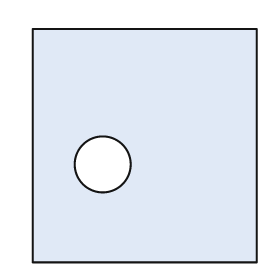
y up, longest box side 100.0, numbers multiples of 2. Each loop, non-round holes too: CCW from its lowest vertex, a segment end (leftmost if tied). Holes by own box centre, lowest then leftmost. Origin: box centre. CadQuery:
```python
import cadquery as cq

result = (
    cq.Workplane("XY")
    .moveTo(-48.0, -50.0)
    .lineTo(48.0, -50.0)
    .lineTo(48.0, 50.0)
    .lineTo(-48.0, 50.0)
    .close()
    .moveTo(-18.0, -8.0)
    .circle(12.0)
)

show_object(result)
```